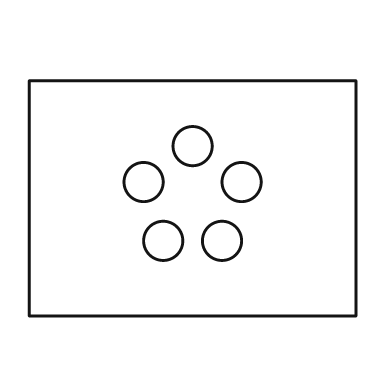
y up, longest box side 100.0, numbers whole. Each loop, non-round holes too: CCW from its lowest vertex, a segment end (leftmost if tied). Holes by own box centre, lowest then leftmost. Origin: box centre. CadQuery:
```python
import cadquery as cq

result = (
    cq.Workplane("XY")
    .moveTo(-50.0, -36.0)
    .lineTo(50.0, -36.0)
    .lineTo(50.0, 36.0)
    .lineTo(-50.0, 36.0)
    .close()
    .moveTo(-9.0, -13.0)
    .circle(6.0)
    .moveTo(9.0, -13.0)
    .circle(6.0)
    .moveTo(-15.0, 5.0)
    .circle(6.0)
    .moveTo(15.0, 5.0)
    .circle(6.0)
    .moveTo(0.0, 16.0)
    .circle(6.0)
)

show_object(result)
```